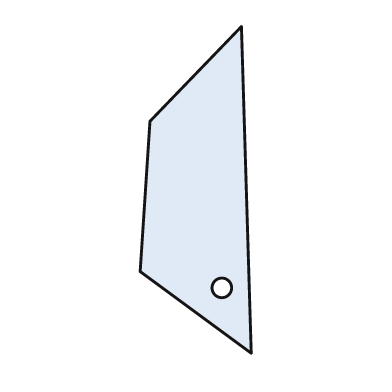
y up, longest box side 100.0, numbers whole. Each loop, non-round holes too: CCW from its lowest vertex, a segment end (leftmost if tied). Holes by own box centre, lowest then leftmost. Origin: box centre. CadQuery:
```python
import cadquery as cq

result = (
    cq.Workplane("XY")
    .moveTo(17.0, -50.0)
    .lineTo(14.0, 50.0)
    .lineTo(-14.0, 21.0)
    .lineTo(-17.0, -25.0)
    .close()
    .moveTo(8.0, -30.0)
    .circle(3.0)
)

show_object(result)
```